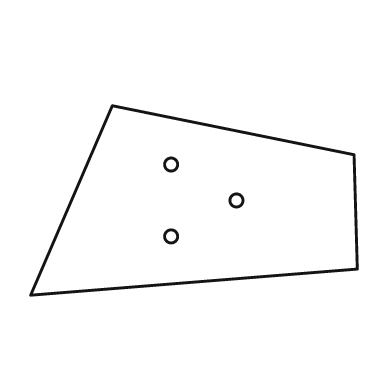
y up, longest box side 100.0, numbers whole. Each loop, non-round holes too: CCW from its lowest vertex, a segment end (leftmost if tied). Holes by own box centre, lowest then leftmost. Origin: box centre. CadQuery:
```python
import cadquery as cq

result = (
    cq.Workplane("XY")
    .moveTo(-50.0, -29.0)
    .lineTo(50.0, -21.0)
    .lineTo(49.0, 14.0)
    .lineTo(-25.0, 29.0)
    .close()
    .moveTo(-7.0, -11.0)
    .circle(2.0)
    .moveTo(13.0, 0.0)
    .circle(2.0)
    .moveTo(-7.0, 11.0)
    .circle(2.0)
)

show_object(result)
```